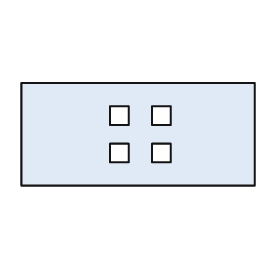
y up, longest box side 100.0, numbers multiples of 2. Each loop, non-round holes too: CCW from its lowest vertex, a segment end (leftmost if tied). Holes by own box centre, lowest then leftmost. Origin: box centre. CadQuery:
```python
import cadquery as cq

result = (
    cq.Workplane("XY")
    .moveTo(-50.0, -22.0)
    .lineTo(50.0, -22.0)
    .lineTo(50.0, 22.0)
    .lineTo(-50.0, 22.0)
    .close()
    .moveTo(-12.0, -12.0)
    .lineTo(-4.0, -12.0)
    .lineTo(-4.0, -4.0)
    .lineTo(-12.0, -4.0)
    .close()
    .moveTo(6.0, -12.0)
    .lineTo(14.0, -12.0)
    .lineTo(14.0, -4.0)
    .lineTo(6.0, -4.0)
    .close()
    .moveTo(-12.0, 4.0)
    .lineTo(-4.0, 4.0)
    .lineTo(-4.0, 12.0)
    .lineTo(-12.0, 12.0)
    .close()
    .moveTo(6.0, 4.0)
    .lineTo(14.0, 4.0)
    .lineTo(14.0, 12.0)
    .lineTo(6.0, 12.0)
    .close()
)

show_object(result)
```